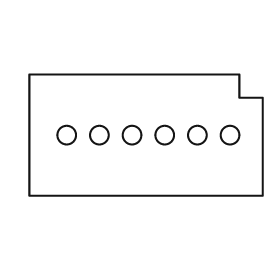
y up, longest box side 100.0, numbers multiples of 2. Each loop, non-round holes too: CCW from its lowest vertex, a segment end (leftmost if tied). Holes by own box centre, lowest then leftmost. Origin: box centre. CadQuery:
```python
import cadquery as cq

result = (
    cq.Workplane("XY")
    .moveTo(-50.0, -26.0)
    .lineTo(50.0, -26.0)
    .lineTo(50.0, 16.0)
    .lineTo(40.0, 16.0)
    .lineTo(40.0, 26.0)
    .lineTo(-50.0, 26.0)
    .close()
    .moveTo(-34.0, 0.0)
    .circle(4.0)
    .moveTo(-20.0, 0.0)
    .circle(4.0)
    .moveTo(-6.0, 0.0)
    .circle(4.0)
    .moveTo(8.0, 0.0)
    .circle(4.0)
    .moveTo(22.0, 0.0)
    .circle(4.0)
    .moveTo(36.0, 0.0)
    .circle(4.0)
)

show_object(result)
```